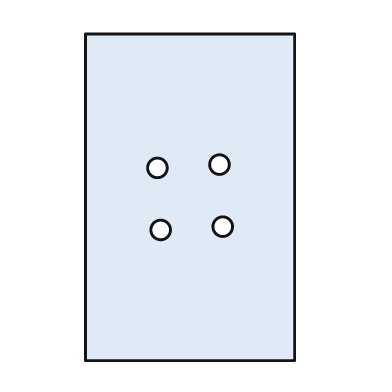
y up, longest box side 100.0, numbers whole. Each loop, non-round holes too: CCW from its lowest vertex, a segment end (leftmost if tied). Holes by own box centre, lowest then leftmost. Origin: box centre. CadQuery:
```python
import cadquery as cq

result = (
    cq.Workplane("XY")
    .moveTo(-32.0, -50.0)
    .lineTo(32.0, -50.0)
    .lineTo(32.0, 50.0)
    .lineTo(-32.0, 50.0)
    .close()
    .moveTo(-9.0, -10.0)
    .circle(3.0)
    .moveTo(10.0, -9.0)
    .circle(3.0)
    .moveTo(-10.0, 9.0)
    .circle(3.0)
    .moveTo(9.0, 10.0)
    .circle(3.0)
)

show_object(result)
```